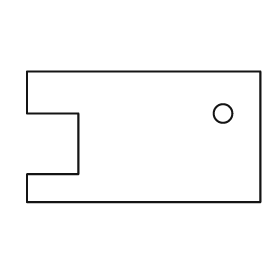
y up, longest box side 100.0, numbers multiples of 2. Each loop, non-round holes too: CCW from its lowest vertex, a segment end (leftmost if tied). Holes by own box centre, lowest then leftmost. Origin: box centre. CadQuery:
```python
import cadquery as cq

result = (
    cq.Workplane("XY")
    .moveTo(-50.0, -28.0)
    .lineTo(50.0, -28.0)
    .lineTo(50.0, 28.0)
    .lineTo(-50.0, 28.0)
    .lineTo(-50.0, 10.0)
    .lineTo(-28.0, 10.0)
    .lineTo(-28.0, -16.0)
    .lineTo(-50.0, -16.0)
    .close()
    .moveTo(34.0, 10.0)
    .circle(4.0)
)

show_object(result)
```